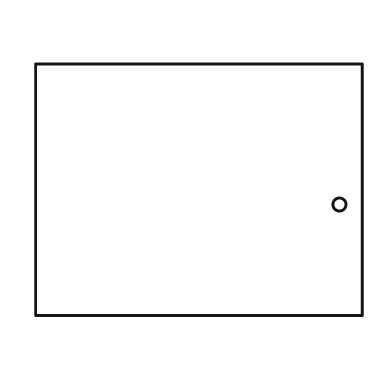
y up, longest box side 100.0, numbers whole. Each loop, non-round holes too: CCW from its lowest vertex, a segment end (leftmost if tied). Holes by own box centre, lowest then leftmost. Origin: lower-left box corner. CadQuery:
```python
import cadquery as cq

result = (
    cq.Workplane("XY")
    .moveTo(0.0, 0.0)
    .lineTo(100.0, 0.0)
    .lineTo(100.0, 77.0)
    .lineTo(0.0, 77.0)
    .close()
    .moveTo(93.0, 34.0)
    .circle(2.0)
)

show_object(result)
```